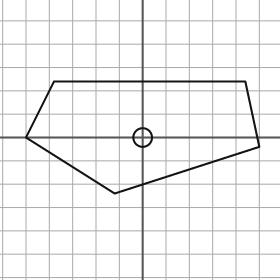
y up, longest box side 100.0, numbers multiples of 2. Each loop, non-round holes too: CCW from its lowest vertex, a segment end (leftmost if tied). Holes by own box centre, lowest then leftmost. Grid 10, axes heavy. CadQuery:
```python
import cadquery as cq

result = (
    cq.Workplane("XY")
    .moveTo(-12.0, -24.0)
    .lineTo(50.0, -4.0)
    .lineTo(44.0, 24.0)
    .lineTo(-38.0, 24.0)
    .lineTo(-50.0, 0.0)
    .close()
    .moveTo(0.0, 0.0)
    .circle(4.0)
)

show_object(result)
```